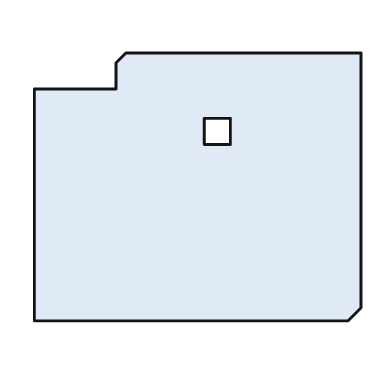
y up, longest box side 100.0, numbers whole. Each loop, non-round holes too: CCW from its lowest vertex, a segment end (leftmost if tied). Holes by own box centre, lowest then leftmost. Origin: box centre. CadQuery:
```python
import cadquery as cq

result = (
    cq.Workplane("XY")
    .moveTo(-50.0, -41.0)
    .lineTo(46.0, -41.0)
    .lineTo(50.0, -37.0)
    .lineTo(50.0, 41.0)
    .lineTo(-22.0, 41.0)
    .lineTo(-25.0, 38.0)
    .lineTo(-25.0, 30.0)
    .lineTo(-50.0, 30.0)
    .close()
    .moveTo(2.0, 13.0)
    .lineTo(10.0, 13.0)
    .lineTo(10.0, 21.0)
    .lineTo(2.0, 21.0)
    .close()
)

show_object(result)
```